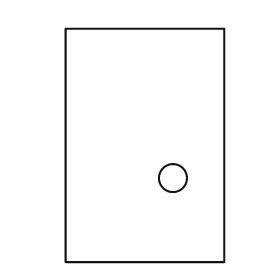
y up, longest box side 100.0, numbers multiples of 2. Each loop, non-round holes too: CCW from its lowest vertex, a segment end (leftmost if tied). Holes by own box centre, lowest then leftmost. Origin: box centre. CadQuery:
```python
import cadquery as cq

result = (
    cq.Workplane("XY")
    .moveTo(-34.0, -50.0)
    .lineTo(34.0, -50.0)
    .lineTo(34.0, 50.0)
    .lineTo(-34.0, 50.0)
    .close()
    .moveTo(12.0, -14.0)
    .circle(6.0)
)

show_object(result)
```